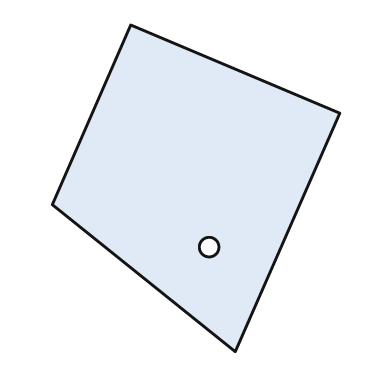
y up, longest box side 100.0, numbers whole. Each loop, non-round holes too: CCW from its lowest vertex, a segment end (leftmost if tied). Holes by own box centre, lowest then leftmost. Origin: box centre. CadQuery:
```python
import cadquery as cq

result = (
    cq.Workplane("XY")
    .moveTo(12.0, -50.0)
    .lineTo(44.0, 23.0)
    .lineTo(-20.0, 50.0)
    .lineTo(-44.0, -5.0)
    .close()
    .moveTo(4.0, -18.0)
    .circle(3.0)
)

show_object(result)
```